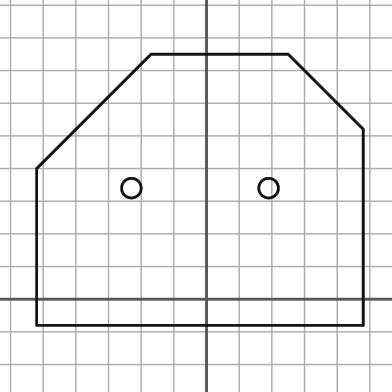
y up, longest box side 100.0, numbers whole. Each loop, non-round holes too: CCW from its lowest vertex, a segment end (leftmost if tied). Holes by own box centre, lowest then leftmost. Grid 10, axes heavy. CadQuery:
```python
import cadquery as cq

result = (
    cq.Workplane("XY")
    .moveTo(-52.0, -8.0)
    .lineTo(48.0, -8.0)
    .lineTo(48.0, 52.0)
    .lineTo(25.0, 75.0)
    .lineTo(-17.0, 75.0)
    .lineTo(-52.0, 40.0)
    .close()
    .moveTo(-23.0, 34.0)
    .circle(3.0)
    .moveTo(19.0, 34.0)
    .circle(3.0)
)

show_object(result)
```